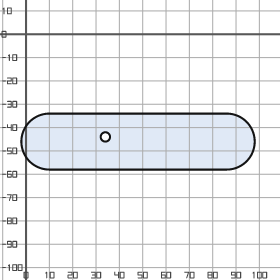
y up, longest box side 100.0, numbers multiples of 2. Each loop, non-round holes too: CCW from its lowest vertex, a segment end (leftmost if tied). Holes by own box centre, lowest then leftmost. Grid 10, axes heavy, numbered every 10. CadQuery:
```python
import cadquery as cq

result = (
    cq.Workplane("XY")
    .moveTo(10.0, -58.0)
    .lineTo(86.0, -58.0)
    .threePointArc((98.0, -46.0), (86.0, -34.0))
    .lineTo(10.0, -34.0)
    .threePointArc((-2.0, -46.0), (10.0, -58.0))
    .close()
    .moveTo(34.0, -44.0)
    .circle(2.0)
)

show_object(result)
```